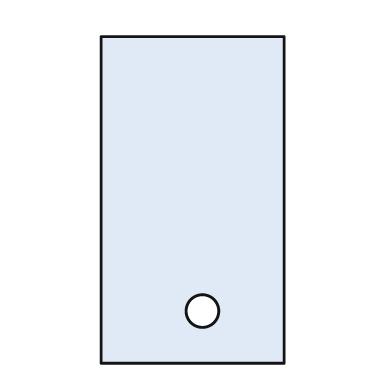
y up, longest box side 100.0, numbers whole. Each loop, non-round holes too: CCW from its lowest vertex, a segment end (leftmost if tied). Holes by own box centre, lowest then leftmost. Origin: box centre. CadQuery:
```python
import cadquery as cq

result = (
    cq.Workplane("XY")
    .moveTo(-28.0, -50.0)
    .lineTo(28.0, -50.0)
    .lineTo(28.0, 50.0)
    .lineTo(-28.0, 50.0)
    .close()
    .moveTo(3.0, -34.0)
    .circle(5.0)
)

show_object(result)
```